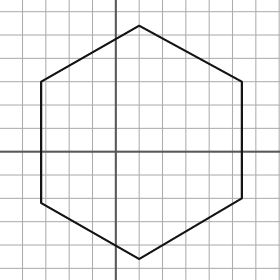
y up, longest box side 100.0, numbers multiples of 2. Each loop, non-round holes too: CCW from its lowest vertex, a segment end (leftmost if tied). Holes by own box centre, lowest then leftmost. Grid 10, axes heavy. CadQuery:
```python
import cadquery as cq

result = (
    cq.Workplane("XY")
    .moveTo(10.0, -46.0)
    .lineTo(54.0, -20.0)
    .lineTo(54.0, 30.0)
    .lineTo(10.0, 54.0)
    .lineTo(-32.0, 30.0)
    .lineTo(-32.0, -22.0)
    .close()
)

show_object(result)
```